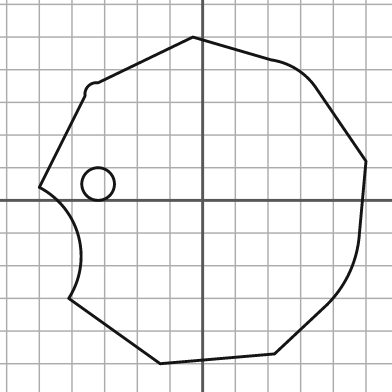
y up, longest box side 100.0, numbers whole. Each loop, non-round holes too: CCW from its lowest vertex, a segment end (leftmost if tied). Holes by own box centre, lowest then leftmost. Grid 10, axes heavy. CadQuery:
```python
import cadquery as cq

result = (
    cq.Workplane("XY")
    .moveTo(-13.0, -50.0)
    .lineTo(22.0, -47.0)
    .lineTo(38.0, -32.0)
    .threePointArc((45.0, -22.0), (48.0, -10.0))
    .lineTo(50.0, 12.0)
    .lineTo(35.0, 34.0)
    .threePointArc((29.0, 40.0), (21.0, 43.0))
    .lineTo(-3.0, 50.0)
    .lineTo(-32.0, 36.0)
    .threePointArc((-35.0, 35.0), (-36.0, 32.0))
    .lineTo(-50.0, 4.0)
    .threePointArc((-38.0, -11.0), (-41.0, -30.0))
    .close()
    .moveTo(-32.0, 5.0)
    .circle(5.0)
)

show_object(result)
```